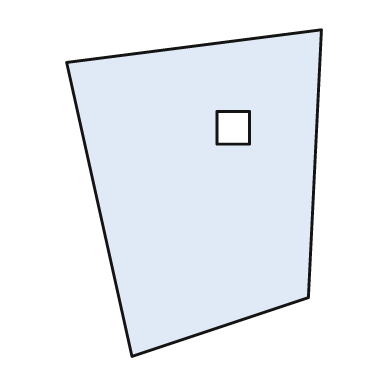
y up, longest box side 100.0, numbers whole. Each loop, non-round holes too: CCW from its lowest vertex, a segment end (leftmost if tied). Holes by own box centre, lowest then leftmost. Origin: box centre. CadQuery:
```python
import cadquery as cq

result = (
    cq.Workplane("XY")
    .moveTo(-19.0, -50.0)
    .lineTo(35.0, -32.0)
    .lineTo(39.0, 50.0)
    .lineTo(-39.0, 40.0)
    .close()
    .moveTo(7.0, 15.0)
    .lineTo(17.0, 15.0)
    .lineTo(17.0, 25.0)
    .lineTo(7.0, 25.0)
    .close()
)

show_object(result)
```